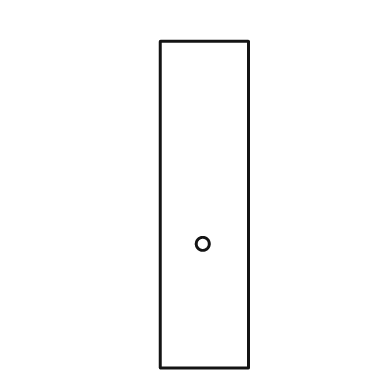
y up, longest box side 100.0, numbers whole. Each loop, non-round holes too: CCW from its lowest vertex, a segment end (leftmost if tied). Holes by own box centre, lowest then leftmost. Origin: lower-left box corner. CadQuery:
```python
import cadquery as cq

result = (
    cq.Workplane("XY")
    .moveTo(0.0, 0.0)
    .lineTo(27.0, 0.0)
    .lineTo(27.0, 100.0)
    .lineTo(0.0, 100.0)
    .close()
    .moveTo(13.0, 38.0)
    .circle(2.0)
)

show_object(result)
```